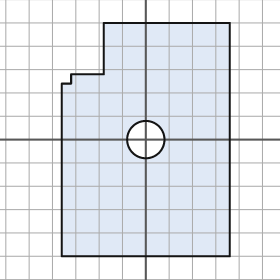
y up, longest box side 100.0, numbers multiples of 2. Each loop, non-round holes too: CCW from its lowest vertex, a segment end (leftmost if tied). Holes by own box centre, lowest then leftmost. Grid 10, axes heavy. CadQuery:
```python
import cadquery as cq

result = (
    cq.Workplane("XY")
    .moveTo(-36.0, -50.0)
    .lineTo(36.0, -50.0)
    .lineTo(36.0, 50.0)
    .lineTo(-18.0, 50.0)
    .lineTo(-18.0, 28.0)
    .lineTo(-32.0, 28.0)
    .lineTo(-32.0, 24.0)
    .lineTo(-36.0, 24.0)
    .close()
    .moveTo(0.0, 0.0)
    .circle(8.0)
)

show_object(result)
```